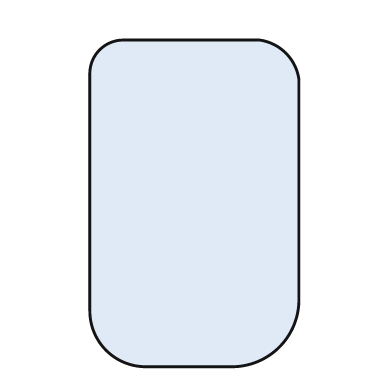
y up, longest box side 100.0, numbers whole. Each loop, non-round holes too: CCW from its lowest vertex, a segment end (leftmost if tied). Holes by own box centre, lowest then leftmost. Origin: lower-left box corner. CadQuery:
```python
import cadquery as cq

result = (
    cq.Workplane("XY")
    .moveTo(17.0, 0.0)
    .lineTo(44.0, 0.0)
    .threePointArc((58.0, 6.0), (64.0, 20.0))
    .lineTo(64.0, 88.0)
    .threePointArc((60.0, 96.0), (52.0, 100.0))
    .lineTo(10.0, 100.0)
    .threePointArc((3.0, 97.0), (0.0, 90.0))
    .lineTo(0.0, 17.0)
    .threePointArc((5.0, 5.0), (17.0, 0.0))
    .close()
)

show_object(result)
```